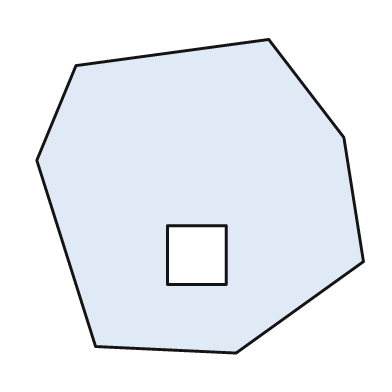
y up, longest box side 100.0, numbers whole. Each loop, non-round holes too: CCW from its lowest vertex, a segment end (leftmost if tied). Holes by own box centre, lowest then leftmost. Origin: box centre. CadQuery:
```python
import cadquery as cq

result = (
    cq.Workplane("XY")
    .moveTo(11.0, -48.0)
    .lineTo(50.0, -20.0)
    .lineTo(44.0, 18.0)
    .lineTo(21.0, 48.0)
    .lineTo(-38.0, 40.0)
    .lineTo(-50.0, 11.0)
    .lineTo(-32.0, -46.0)
    .close()
    .moveTo(-10.0, -27.0)
    .lineTo(8.0, -27.0)
    .lineTo(8.0, -9.0)
    .lineTo(-10.0, -9.0)
    .close()
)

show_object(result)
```